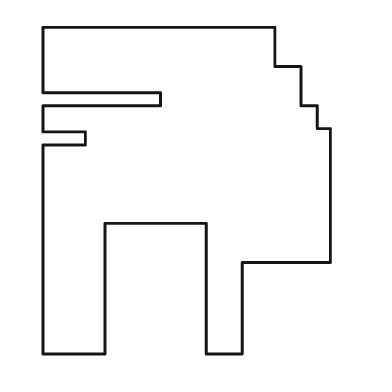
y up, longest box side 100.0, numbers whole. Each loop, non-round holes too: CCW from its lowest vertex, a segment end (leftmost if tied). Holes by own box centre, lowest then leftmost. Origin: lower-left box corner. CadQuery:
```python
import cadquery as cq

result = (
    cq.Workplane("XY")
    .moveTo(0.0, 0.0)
    .lineTo(19.0, 0.0)
    .lineTo(19.0, 40.0)
    .lineTo(50.0, 40.0)
    .lineTo(50.0, 0.0)
    .lineTo(61.0, 0.0)
    .lineTo(61.0, 28.0)
    .lineTo(88.0, 28.0)
    .lineTo(88.0, 69.0)
    .lineTo(84.0, 69.0)
    .lineTo(84.0, 76.0)
    .lineTo(79.0, 76.0)
    .lineTo(79.0, 88.0)
    .lineTo(71.0, 88.0)
    .lineTo(71.0, 100.0)
    .lineTo(0.0, 100.0)
    .lineTo(0.0, 80.0)
    .lineTo(36.0, 80.0)
    .lineTo(36.0, 76.0)
    .lineTo(0.0, 76.0)
    .lineTo(0.0, 68.0)
    .lineTo(13.0, 68.0)
    .lineTo(13.0, 64.0)
    .lineTo(0.0, 64.0)
    .close()
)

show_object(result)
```